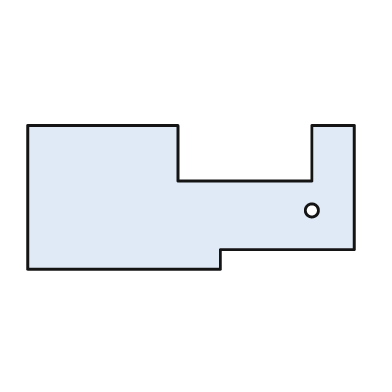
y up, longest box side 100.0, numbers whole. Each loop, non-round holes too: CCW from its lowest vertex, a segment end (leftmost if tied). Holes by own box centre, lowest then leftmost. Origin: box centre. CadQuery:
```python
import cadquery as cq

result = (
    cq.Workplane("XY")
    .moveTo(-50.0, -22.0)
    .lineTo(9.0, -22.0)
    .lineTo(9.0, -16.0)
    .lineTo(50.0, -16.0)
    .lineTo(50.0, 22.0)
    .lineTo(37.0, 22.0)
    .lineTo(37.0, 5.0)
    .lineTo(-4.0, 5.0)
    .lineTo(-4.0, 22.0)
    .lineTo(-50.0, 22.0)
    .close()
    .moveTo(37.0, -4.0)
    .circle(2.0)
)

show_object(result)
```